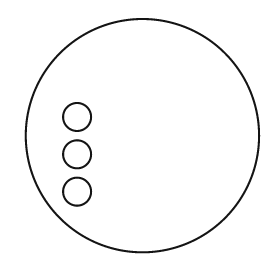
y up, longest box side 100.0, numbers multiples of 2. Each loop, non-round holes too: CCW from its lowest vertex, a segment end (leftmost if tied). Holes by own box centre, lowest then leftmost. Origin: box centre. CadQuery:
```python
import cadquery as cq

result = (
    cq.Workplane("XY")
    .moveTo(0.0, 0.0)
    .circle(50.0)
    .moveTo(-28.0, -24.0)
    .circle(6.0)
    .moveTo(-28.0, -8.0)
    .circle(6.0)
    .moveTo(-28.0, 8.0)
    .circle(6.0)
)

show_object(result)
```